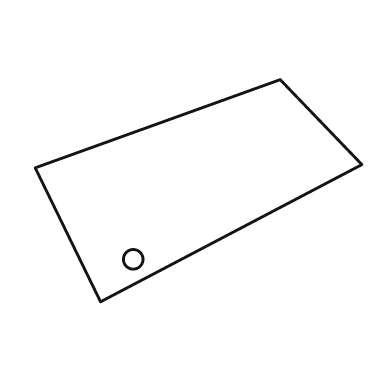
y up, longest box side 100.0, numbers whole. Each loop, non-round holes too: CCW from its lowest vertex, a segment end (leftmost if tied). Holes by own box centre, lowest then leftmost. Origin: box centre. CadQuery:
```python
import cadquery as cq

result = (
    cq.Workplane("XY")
    .moveTo(-30.0, -34.0)
    .lineTo(50.0, 8.0)
    .lineTo(25.0, 34.0)
    .lineTo(-50.0, 7.0)
    .close()
    .moveTo(-20.0, -21.0)
    .circle(3.0)
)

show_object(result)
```